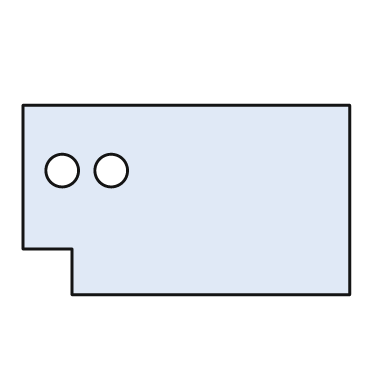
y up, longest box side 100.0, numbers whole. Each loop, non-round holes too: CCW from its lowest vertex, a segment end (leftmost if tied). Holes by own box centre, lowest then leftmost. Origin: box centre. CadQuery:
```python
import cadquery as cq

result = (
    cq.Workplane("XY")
    .moveTo(-35.0, -29.0)
    .lineTo(50.0, -29.0)
    .lineTo(50.0, 29.0)
    .lineTo(-50.0, 29.0)
    .lineTo(-50.0, -15.0)
    .lineTo(-35.0, -15.0)
    .close()
    .moveTo(-38.0, 9.0)
    .circle(5.0)
    .moveTo(-23.0, 9.0)
    .circle(5.0)
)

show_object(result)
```